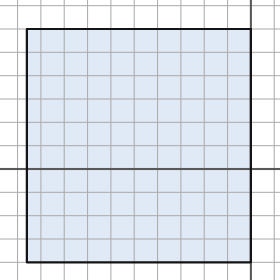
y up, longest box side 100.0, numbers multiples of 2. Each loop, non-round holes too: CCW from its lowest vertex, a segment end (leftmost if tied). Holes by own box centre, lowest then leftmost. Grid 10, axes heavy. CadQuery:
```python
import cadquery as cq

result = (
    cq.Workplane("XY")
    .moveTo(-96.0, -40.0)
    .lineTo(0.0, -40.0)
    .lineTo(0.0, 60.0)
    .lineTo(-96.0, 60.0)
    .close()
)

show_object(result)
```